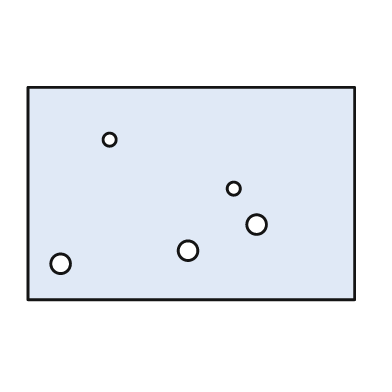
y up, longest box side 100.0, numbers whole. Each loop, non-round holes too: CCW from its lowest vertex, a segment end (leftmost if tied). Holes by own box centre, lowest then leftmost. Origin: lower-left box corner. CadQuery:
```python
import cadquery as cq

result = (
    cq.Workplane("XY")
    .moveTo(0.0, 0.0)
    .lineTo(100.0, 0.0)
    .lineTo(100.0, 65.0)
    .lineTo(0.0, 65.0)
    .close()
    .moveTo(10.0, 11.0)
    .circle(3.0)
    .moveTo(49.0, 15.0)
    .circle(3.0)
    .moveTo(70.0, 23.0)
    .circle(3.0)
    .moveTo(63.0, 34.0)
    .circle(2.0)
    .moveTo(25.0, 49.0)
    .circle(2.0)
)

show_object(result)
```